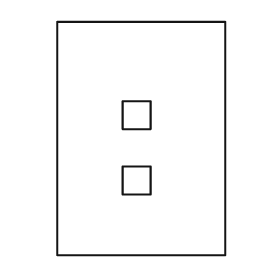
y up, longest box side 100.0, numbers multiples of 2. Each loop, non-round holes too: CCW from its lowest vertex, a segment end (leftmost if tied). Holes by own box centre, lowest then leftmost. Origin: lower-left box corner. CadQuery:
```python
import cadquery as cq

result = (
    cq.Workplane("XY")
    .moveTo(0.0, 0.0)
    .lineTo(72.0, 0.0)
    .lineTo(72.0, 100.0)
    .lineTo(0.0, 100.0)
    .close()
    .moveTo(28.0, 26.0)
    .lineTo(40.0, 26.0)
    .lineTo(40.0, 38.0)
    .lineTo(28.0, 38.0)
    .close()
    .moveTo(28.0, 54.0)
    .lineTo(40.0, 54.0)
    .lineTo(40.0, 66.0)
    .lineTo(28.0, 66.0)
    .close()
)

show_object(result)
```